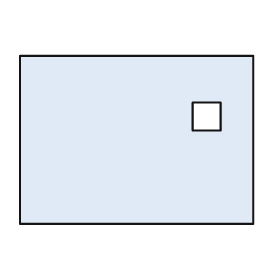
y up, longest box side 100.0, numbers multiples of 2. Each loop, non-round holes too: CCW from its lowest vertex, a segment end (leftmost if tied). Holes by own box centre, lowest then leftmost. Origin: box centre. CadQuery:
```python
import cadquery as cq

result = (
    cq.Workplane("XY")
    .moveTo(-50.0, -36.0)
    .lineTo(50.0, -36.0)
    .lineTo(50.0, 36.0)
    .lineTo(-50.0, 36.0)
    .close()
    .moveTo(24.0, 4.0)
    .lineTo(36.0, 4.0)
    .lineTo(36.0, 16.0)
    .lineTo(24.0, 16.0)
    .close()
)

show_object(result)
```